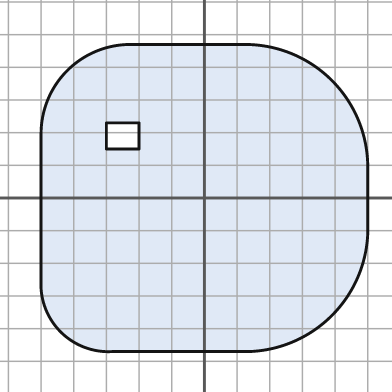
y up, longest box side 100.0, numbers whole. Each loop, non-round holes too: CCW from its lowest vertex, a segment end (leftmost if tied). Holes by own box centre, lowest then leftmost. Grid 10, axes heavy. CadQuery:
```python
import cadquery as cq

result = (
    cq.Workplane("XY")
    .moveTo(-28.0, -47.0)
    .lineTo(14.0, -47.0)
    .threePointArc((39.0, -36.0), (50.0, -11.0))
    .lineTo(50.0, 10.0)
    .threePointArc((39.0, 36.0), (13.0, 47.0))
    .lineTo(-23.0, 47.0)
    .threePointArc((-42.0, 39.0), (-50.0, 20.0))
    .lineTo(-50.0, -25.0)
    .threePointArc((-44.0, -41.0), (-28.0, -47.0))
    .close()
    .moveTo(-30.0, 15.0)
    .lineTo(-20.0, 15.0)
    .lineTo(-20.0, 23.0)
    .lineTo(-30.0, 23.0)
    .close()
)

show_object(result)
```